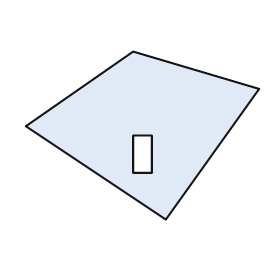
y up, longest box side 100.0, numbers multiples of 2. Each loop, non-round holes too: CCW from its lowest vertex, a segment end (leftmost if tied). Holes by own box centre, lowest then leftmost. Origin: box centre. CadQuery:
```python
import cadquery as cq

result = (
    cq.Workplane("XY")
    .moveTo(10.0, -36.0)
    .lineTo(50.0, 20.0)
    .lineTo(-4.0, 36.0)
    .lineTo(-50.0, 4.0)
    .close()
    .moveTo(-4.0, -16.0)
    .lineTo(4.0, -16.0)
    .lineTo(4.0, 0.0)
    .lineTo(-4.0, 0.0)
    .close()
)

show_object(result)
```